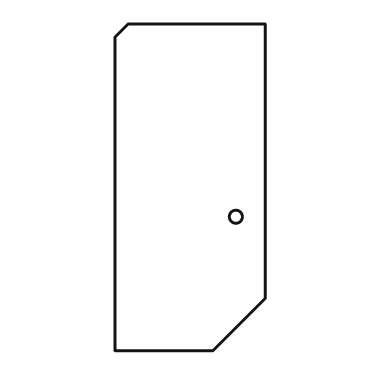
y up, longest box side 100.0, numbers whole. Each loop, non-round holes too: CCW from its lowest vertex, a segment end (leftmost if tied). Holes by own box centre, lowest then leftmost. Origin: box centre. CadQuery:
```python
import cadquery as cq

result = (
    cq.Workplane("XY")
    .moveTo(-23.0, -50.0)
    .lineTo(7.0, -50.0)
    .lineTo(23.0, -34.0)
    .lineTo(23.0, 50.0)
    .lineTo(-19.0, 50.0)
    .lineTo(-23.0, 46.0)
    .close()
    .moveTo(14.0, -9.0)
    .circle(2.0)
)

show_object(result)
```